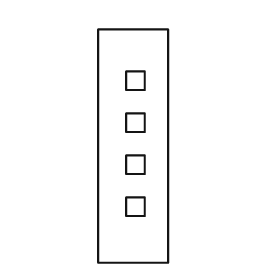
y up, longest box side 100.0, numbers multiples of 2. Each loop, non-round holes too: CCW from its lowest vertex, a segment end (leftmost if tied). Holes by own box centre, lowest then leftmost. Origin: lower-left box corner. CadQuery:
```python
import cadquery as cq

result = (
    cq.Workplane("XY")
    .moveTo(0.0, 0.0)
    .lineTo(30.0, 0.0)
    .lineTo(30.0, 100.0)
    .lineTo(0.0, 100.0)
    .close()
    .moveTo(12.0, 20.0)
    .lineTo(20.0, 20.0)
    .lineTo(20.0, 28.0)
    .lineTo(12.0, 28.0)
    .close()
    .moveTo(12.0, 38.0)
    .lineTo(20.0, 38.0)
    .lineTo(20.0, 46.0)
    .lineTo(12.0, 46.0)
    .close()
    .moveTo(12.0, 56.0)
    .lineTo(20.0, 56.0)
    .lineTo(20.0, 64.0)
    .lineTo(12.0, 64.0)
    .close()
    .moveTo(12.0, 74.0)
    .lineTo(20.0, 74.0)
    .lineTo(20.0, 82.0)
    .lineTo(12.0, 82.0)
    .close()
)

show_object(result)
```